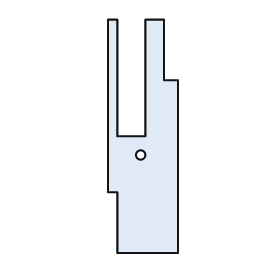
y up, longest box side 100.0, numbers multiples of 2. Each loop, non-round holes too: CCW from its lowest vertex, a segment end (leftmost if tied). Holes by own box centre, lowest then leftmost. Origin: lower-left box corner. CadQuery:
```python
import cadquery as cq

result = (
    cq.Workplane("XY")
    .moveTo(4.0, 0.0)
    .lineTo(30.0, 0.0)
    .lineTo(30.0, 74.0)
    .lineTo(24.0, 74.0)
    .lineTo(24.0, 100.0)
    .lineTo(16.0, 100.0)
    .lineTo(16.0, 50.0)
    .lineTo(4.0, 50.0)
    .lineTo(4.0, 100.0)
    .lineTo(0.0, 100.0)
    .lineTo(0.0, 26.0)
    .lineTo(4.0, 26.0)
    .close()
    .moveTo(14.0, 42.0)
    .circle(2.0)
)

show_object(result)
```